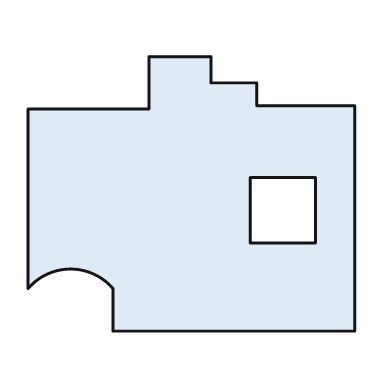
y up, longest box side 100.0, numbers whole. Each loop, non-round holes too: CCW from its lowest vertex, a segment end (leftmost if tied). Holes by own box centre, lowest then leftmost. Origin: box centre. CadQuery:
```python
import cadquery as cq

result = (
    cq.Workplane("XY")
    .moveTo(-24.0, -42.0)
    .lineTo(50.0, -42.0)
    .lineTo(50.0, 27.0)
    .lineTo(20.0, 27.0)
    .lineTo(20.0, 34.0)
    .lineTo(6.0, 34.0)
    .lineTo(6.0, 42.0)
    .lineTo(-13.0, 42.0)
    .lineTo(-13.0, 26.0)
    .lineTo(-50.0, 26.0)
    .lineTo(-50.0, -29.0)
    .threePointArc((-37.0, -23.0), (-24.0, -29.0))
    .close()
    .moveTo(18.0, -15.0)
    .lineTo(38.0, -15.0)
    .lineTo(38.0, 5.0)
    .lineTo(18.0, 5.0)
    .close()
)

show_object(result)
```